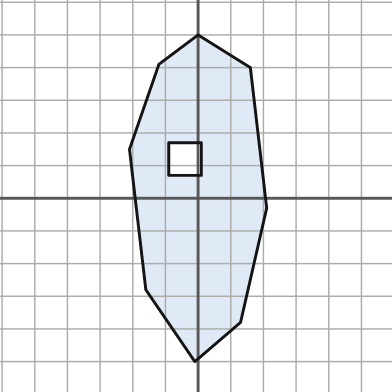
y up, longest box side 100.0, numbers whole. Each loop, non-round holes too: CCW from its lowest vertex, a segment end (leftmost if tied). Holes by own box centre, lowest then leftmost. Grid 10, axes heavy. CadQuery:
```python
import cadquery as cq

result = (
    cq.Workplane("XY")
    .moveTo(-1.0, -50.0)
    .lineTo(13.0, -38.0)
    .lineTo(21.0, -3.0)
    .lineTo(16.0, 40.0)
    .lineTo(0.0, 50.0)
    .lineTo(-12.0, 41.0)
    .lineTo(-21.0, 15.0)
    .lineTo(-16.0, -28.0)
    .close()
    .moveTo(-9.0, 7.0)
    .lineTo(1.0, 7.0)
    .lineTo(1.0, 17.0)
    .lineTo(-9.0, 17.0)
    .close()
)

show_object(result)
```